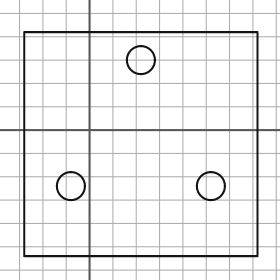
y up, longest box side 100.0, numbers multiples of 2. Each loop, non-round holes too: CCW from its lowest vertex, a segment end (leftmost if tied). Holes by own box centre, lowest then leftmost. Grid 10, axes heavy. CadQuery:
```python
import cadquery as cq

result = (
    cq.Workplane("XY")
    .moveTo(-28.0, -54.0)
    .lineTo(72.0, -54.0)
    .lineTo(72.0, 42.0)
    .lineTo(-28.0, 42.0)
    .close()
    .moveTo(-8.0, -24.0)
    .circle(6.0)
    .moveTo(52.0, -24.0)
    .circle(6.0)
    .moveTo(22.0, 30.0)
    .circle(6.0)
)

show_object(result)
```